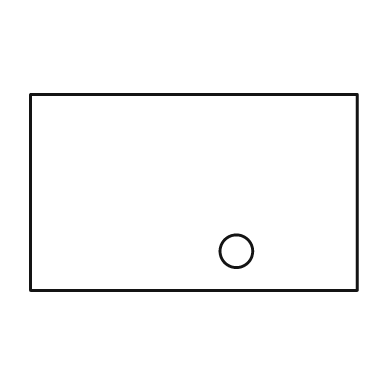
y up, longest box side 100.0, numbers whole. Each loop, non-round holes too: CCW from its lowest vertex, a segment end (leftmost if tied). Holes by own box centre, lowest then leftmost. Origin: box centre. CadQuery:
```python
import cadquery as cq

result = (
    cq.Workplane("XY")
    .moveTo(-50.0, -30.0)
    .lineTo(50.0, -30.0)
    .lineTo(50.0, 30.0)
    .lineTo(-50.0, 30.0)
    .close()
    .moveTo(13.0, -18.0)
    .circle(5.0)
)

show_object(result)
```